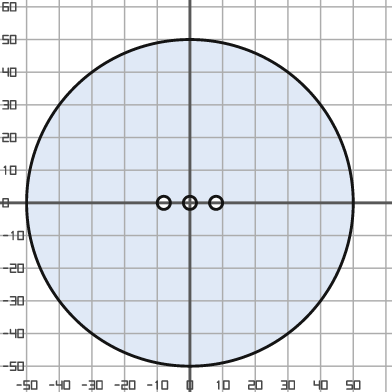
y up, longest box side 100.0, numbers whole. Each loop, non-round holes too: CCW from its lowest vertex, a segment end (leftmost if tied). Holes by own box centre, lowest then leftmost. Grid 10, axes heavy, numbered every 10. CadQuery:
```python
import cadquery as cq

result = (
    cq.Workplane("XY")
    .moveTo(0.0, 0.0)
    .circle(50.0)
    .moveTo(-8.0, 0.0)
    .circle(2.0)
    .moveTo(0.0, 0.0)
    .circle(2.0)
    .moveTo(8.0, 0.0)
    .circle(2.0)
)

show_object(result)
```